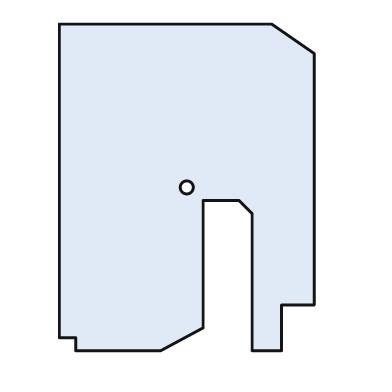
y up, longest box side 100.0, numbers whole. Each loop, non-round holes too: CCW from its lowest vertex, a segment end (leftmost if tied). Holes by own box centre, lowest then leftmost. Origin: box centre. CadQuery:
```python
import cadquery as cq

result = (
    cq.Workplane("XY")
    .moveTo(-34.0, -50.0)
    .lineTo(-8.0, -50.0)
    .lineTo(5.0, -43.0)
    .lineTo(5.0, -4.0)
    .lineTo(16.0, -4.0)
    .lineTo(20.0, -8.0)
    .lineTo(20.0, -50.0)
    .lineTo(29.0, -50.0)
    .lineTo(29.0, -36.0)
    .lineTo(39.0, -36.0)
    .lineTo(39.0, 41.0)
    .lineTo(26.0, 50.0)
    .lineTo(-39.0, 50.0)
    .lineTo(-39.0, -46.0)
    .lineTo(-34.0, -46.0)
    .close()
    .moveTo(0.0, 0.0)
    .circle(2.0)
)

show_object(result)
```